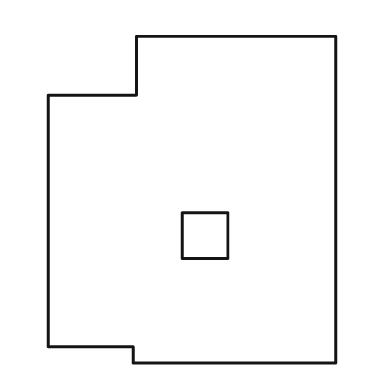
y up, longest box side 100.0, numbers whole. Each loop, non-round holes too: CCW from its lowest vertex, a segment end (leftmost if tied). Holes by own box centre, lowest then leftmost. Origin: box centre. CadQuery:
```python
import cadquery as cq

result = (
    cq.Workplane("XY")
    .moveTo(-18.0, -50.0)
    .lineTo(44.0, -50.0)
    .lineTo(44.0, 50.0)
    .lineTo(-17.0, 50.0)
    .lineTo(-17.0, 32.0)
    .lineTo(-44.0, 32.0)
    .lineTo(-44.0, -45.0)
    .lineTo(-18.0, -45.0)
    .close()
    .moveTo(-3.0, -18.0)
    .lineTo(11.0, -18.0)
    .lineTo(11.0, -4.0)
    .lineTo(-3.0, -4.0)
    .close()
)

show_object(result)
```